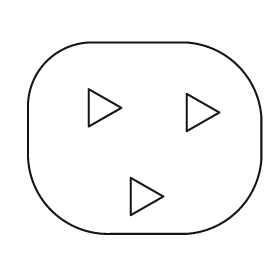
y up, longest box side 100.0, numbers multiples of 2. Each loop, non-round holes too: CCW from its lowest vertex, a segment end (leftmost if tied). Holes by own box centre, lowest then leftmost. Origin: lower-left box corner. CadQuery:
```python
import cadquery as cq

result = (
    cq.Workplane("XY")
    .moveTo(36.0, 0.0)
    .lineTo(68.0, 0.0)
    .threePointArc((90.0, 10.0), (100.0, 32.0))
    .lineTo(100.0, 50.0)
    .threePointArc((90.0, 72.0), (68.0, 82.0))
    .lineTo(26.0, 82.0)
    .threePointArc((8.0, 74.0), (0.0, 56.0))
    .lineTo(0.0, 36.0)
    .threePointArc((10.0, 10.0), (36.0, 0.0))
    .close()
    .moveTo(44.0, 8.0)
    .lineTo(58.0, 16.0)
    .lineTo(44.0, 24.0)
    .close()
    .moveTo(68.0, 44.0)
    .lineTo(82.0, 52.0)
    .lineTo(68.0, 60.0)
    .close()
    .moveTo(26.0, 46.0)
    .lineTo(40.0, 54.0)
    .lineTo(26.0, 62.0)
    .close()
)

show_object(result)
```